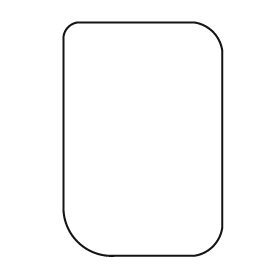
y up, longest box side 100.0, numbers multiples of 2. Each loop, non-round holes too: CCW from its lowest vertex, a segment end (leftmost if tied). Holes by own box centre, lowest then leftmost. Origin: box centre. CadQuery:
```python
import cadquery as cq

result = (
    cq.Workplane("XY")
    .moveTo(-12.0, -50.0)
    .lineTo(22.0, -50.0)
    .threePointArc((30.0, -46.0), (34.0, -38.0))
    .lineTo(34.0, 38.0)
    .threePointArc((30.0, 46.0), (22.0, 50.0))
    .lineTo(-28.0, 50.0)
    .threePointArc((-32.0, 48.0), (-34.0, 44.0))
    .lineTo(-34.0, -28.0)
    .threePointArc((-28.0, -44.0), (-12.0, -50.0))
    .close()
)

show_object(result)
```